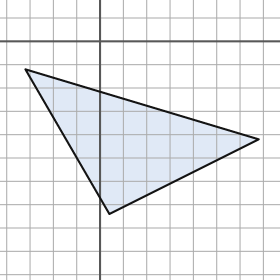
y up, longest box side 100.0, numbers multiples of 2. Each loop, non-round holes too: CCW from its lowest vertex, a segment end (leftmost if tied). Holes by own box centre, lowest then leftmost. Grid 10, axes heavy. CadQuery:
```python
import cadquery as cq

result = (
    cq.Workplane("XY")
    .moveTo(4.0, -74.0)
    .lineTo(68.0, -42.0)
    .lineTo(-32.0, -12.0)
    .close()
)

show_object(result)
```